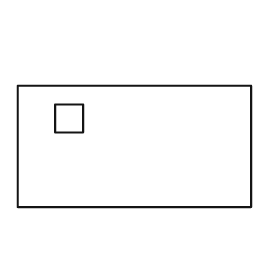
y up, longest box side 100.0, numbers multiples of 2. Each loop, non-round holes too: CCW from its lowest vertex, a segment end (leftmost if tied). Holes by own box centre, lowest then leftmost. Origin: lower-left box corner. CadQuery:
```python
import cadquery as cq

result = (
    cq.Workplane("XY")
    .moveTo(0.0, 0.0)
    .lineTo(100.0, 0.0)
    .lineTo(100.0, 52.0)
    .lineTo(0.0, 52.0)
    .close()
    .moveTo(16.0, 32.0)
    .lineTo(28.0, 32.0)
    .lineTo(28.0, 44.0)
    .lineTo(16.0, 44.0)
    .close()
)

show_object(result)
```